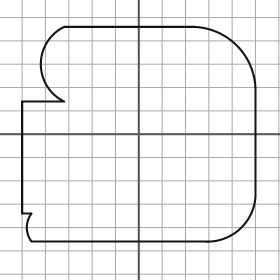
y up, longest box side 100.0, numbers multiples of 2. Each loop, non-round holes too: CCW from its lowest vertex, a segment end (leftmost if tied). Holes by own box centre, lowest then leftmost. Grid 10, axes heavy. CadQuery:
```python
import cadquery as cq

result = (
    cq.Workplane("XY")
    .moveTo(-46.0, -46.0)
    .lineTo(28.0, -46.0)
    .threePointArc((44.0, -40.0), (50.0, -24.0))
    .lineTo(50.0, 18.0)
    .threePointArc((42.0, 38.0), (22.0, 46.0))
    .lineTo(-32.0, 46.0)
    .threePointArc((-42.0, 30.0), (-32.0, 14.0))
    .lineTo(-50.0, 14.0)
    .lineTo(-50.0, -34.0)
    .lineTo(-46.0, -34.0)
    .threePointArc((-48.0, -40.0), (-46.0, -46.0))
    .close()
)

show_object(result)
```